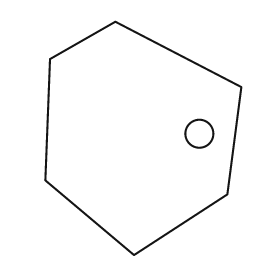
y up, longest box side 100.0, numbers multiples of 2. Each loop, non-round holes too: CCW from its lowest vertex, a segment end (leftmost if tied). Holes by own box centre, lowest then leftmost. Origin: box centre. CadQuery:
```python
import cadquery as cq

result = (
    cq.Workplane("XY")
    .moveTo(-4.0, -50.0)
    .lineTo(36.0, -24.0)
    .lineTo(42.0, 22.0)
    .lineTo(-12.0, 50.0)
    .lineTo(-40.0, 34.0)
    .lineTo(-42.0, -18.0)
    .close()
    .moveTo(24.0, 2.0)
    .circle(6.0)
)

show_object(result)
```